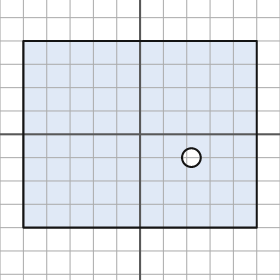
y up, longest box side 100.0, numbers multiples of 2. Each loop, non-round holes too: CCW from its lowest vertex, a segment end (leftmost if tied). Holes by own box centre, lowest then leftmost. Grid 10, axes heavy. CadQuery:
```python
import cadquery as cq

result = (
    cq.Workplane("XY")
    .moveTo(-50.0, -40.0)
    .lineTo(50.0, -40.0)
    .lineTo(50.0, 40.0)
    .lineTo(-50.0, 40.0)
    .close()
    .moveTo(22.0, -10.0)
    .circle(4.0)
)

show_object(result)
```